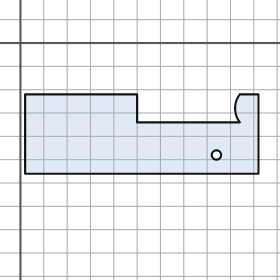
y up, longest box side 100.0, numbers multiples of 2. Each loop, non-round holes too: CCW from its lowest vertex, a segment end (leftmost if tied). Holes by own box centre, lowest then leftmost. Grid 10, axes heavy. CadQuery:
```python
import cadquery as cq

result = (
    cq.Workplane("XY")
    .moveTo(2.0, -56.0)
    .lineTo(102.0, -56.0)
    .lineTo(102.0, -22.0)
    .lineTo(94.0, -22.0)
    .threePointArc((92.0, -28.0), (94.0, -34.0))
    .lineTo(50.0, -34.0)
    .lineTo(50.0, -22.0)
    .lineTo(2.0, -22.0)
    .close()
    .moveTo(84.0, -48.0)
    .circle(2.0)
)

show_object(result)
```